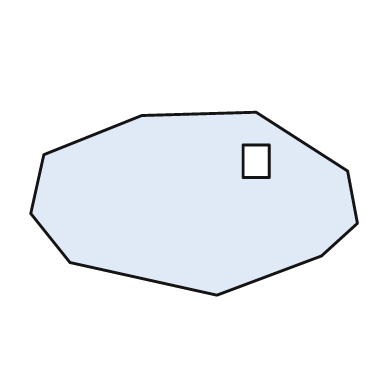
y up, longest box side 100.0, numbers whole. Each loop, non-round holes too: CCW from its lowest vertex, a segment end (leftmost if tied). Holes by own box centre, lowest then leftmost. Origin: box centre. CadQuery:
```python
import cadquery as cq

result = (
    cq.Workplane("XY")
    .moveTo(7.0, -28.0)
    .lineTo(39.0, -16.0)
    .lineTo(50.0, -6.0)
    .lineTo(47.0, 10.0)
    .lineTo(19.0, 28.0)
    .lineTo(-16.0, 27.0)
    .lineTo(-46.0, 15.0)
    .lineTo(-50.0, -3.0)
    .lineTo(-38.0, -18.0)
    .close()
    .moveTo(15.0, 8.0)
    .lineTo(23.0, 8.0)
    .lineTo(23.0, 18.0)
    .lineTo(15.0, 18.0)
    .close()
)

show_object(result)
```